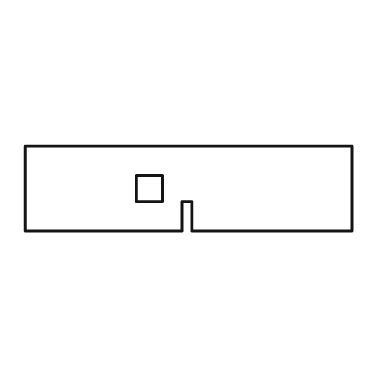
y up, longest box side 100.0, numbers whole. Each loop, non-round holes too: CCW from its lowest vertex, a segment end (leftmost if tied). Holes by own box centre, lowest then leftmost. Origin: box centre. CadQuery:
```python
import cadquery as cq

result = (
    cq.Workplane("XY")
    .moveTo(-50.0, -13.0)
    .lineTo(-2.0, -13.0)
    .lineTo(-2.0, -4.0)
    .lineTo(1.0, -4.0)
    .lineTo(1.0, -13.0)
    .lineTo(50.0, -13.0)
    .lineTo(50.0, 13.0)
    .lineTo(-50.0, 13.0)
    .close()
    .moveTo(-16.0, -4.0)
    .lineTo(-8.0, -4.0)
    .lineTo(-8.0, 4.0)
    .lineTo(-16.0, 4.0)
    .close()
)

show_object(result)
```